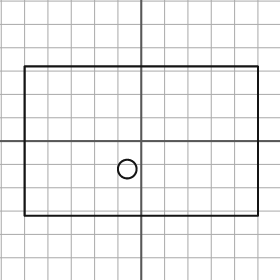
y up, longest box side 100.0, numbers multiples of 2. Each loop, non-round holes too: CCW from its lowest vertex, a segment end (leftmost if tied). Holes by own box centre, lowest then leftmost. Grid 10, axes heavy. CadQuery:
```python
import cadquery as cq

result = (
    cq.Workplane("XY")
    .moveTo(-50.0, -32.0)
    .lineTo(50.0, -32.0)
    .lineTo(50.0, 32.0)
    .lineTo(-50.0, 32.0)
    .close()
    .moveTo(-6.0, -12.0)
    .circle(4.0)
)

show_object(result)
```